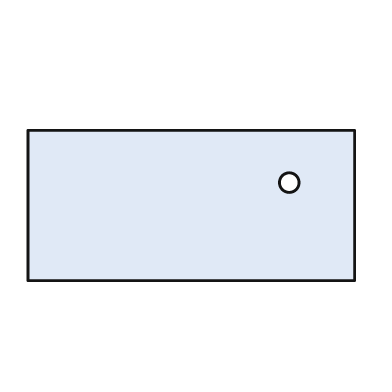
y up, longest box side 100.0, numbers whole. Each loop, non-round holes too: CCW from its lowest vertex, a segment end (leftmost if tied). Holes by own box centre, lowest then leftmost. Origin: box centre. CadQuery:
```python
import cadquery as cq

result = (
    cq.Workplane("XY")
    .moveTo(-50.0, -23.0)
    .lineTo(50.0, -23.0)
    .lineTo(50.0, 23.0)
    .lineTo(-50.0, 23.0)
    .close()
    .moveTo(30.0, 7.0)
    .circle(3.0)
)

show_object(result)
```